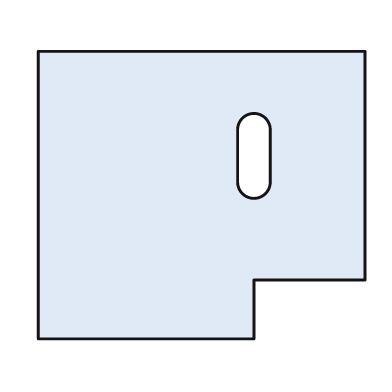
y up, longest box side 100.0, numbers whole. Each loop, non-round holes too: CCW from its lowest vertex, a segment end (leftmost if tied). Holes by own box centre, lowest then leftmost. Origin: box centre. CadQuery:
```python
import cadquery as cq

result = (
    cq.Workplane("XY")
    .moveTo(-50.0, -44.0)
    .lineTo(16.0, -44.0)
    .lineTo(16.0, -26.0)
    .lineTo(50.0, -26.0)
    .lineTo(50.0, 44.0)
    .lineTo(-50.0, 44.0)
    .close()
    .moveTo(11.0, 4.0)
    .threePointArc((16.0, -1.0), (21.0, 4.0))
    .lineTo(21.0, 20.0)
    .threePointArc((16.0, 25.0), (11.0, 20.0))
    .close()
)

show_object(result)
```